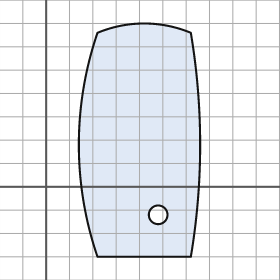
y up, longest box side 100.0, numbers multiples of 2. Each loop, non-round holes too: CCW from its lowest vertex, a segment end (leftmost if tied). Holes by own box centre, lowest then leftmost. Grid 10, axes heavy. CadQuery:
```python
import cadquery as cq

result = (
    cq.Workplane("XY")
    .moveTo(22.0, -30.0)
    .lineTo(62.0, -30.0)
    .threePointArc((66.0, 18.0), (62.0, 66.0))
    .threePointArc((42.0, 70.0), (22.0, 66.0))
    .threePointArc((14.0, 18.0), (22.0, -30.0))
    .close()
    .moveTo(48.0, -12.0)
    .circle(4.0)
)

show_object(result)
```